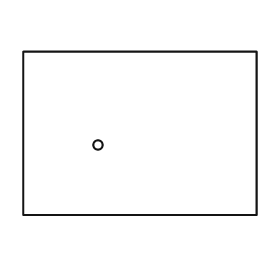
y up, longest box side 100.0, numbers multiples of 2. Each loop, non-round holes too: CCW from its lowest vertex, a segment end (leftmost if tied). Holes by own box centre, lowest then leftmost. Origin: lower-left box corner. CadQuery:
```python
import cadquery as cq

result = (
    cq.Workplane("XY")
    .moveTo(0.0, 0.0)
    .lineTo(100.0, 0.0)
    .lineTo(100.0, 70.0)
    .lineTo(0.0, 70.0)
    .close()
    .moveTo(32.0, 30.0)
    .circle(2.0)
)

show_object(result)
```